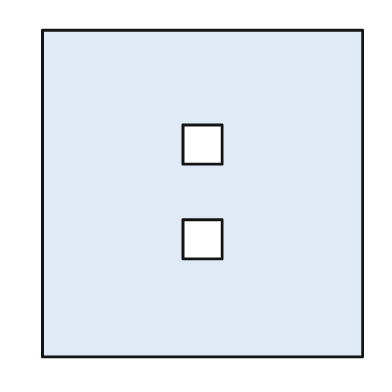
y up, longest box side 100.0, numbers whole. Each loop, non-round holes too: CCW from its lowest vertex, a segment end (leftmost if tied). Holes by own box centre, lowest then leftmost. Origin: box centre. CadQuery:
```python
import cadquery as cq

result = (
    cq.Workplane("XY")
    .moveTo(-49.0, -50.0)
    .lineTo(49.0, -50.0)
    .lineTo(49.0, 50.0)
    .lineTo(-49.0, 50.0)
    .close()
    .moveTo(-6.0, -20.0)
    .lineTo(6.0, -20.0)
    .lineTo(6.0, -8.0)
    .lineTo(-6.0, -8.0)
    .close()
    .moveTo(-6.0, 9.0)
    .lineTo(6.0, 9.0)
    .lineTo(6.0, 21.0)
    .lineTo(-6.0, 21.0)
    .close()
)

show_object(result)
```